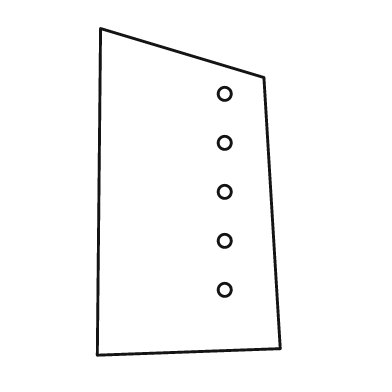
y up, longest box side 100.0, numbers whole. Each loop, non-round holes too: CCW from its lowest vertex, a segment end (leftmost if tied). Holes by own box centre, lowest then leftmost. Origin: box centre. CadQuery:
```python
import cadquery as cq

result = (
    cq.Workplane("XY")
    .moveTo(-28.0, -50.0)
    .lineTo(28.0, -48.0)
    .lineTo(23.0, 35.0)
    .lineTo(-27.0, 50.0)
    .close()
    .moveTo(11.0, -30.0)
    .circle(2.0)
    .moveTo(11.0, -15.0)
    .circle(2.0)
    .moveTo(11.0, 0.0)
    .circle(2.0)
    .moveTo(11.0, 15.0)
    .circle(2.0)
    .moveTo(11.0, 30.0)
    .circle(2.0)
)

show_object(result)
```